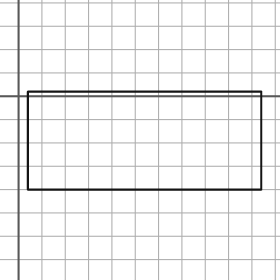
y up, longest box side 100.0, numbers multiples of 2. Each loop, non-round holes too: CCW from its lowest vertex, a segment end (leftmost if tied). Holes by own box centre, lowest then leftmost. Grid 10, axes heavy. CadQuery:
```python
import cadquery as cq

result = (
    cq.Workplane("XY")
    .moveTo(4.0, -40.0)
    .lineTo(104.0, -40.0)
    .lineTo(104.0, 2.0)
    .lineTo(4.0, 2.0)
    .close()
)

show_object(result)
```